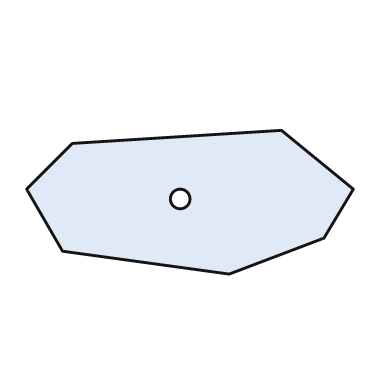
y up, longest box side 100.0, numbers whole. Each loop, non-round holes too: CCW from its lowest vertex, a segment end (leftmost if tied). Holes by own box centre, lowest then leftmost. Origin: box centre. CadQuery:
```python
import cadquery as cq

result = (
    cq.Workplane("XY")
    .moveTo(12.0, -22.0)
    .lineTo(41.0, -11.0)
    .lineTo(50.0, 4.0)
    .lineTo(28.0, 22.0)
    .lineTo(-36.0, 18.0)
    .lineTo(-50.0, 4.0)
    .lineTo(-39.0, -15.0)
    .close()
    .moveTo(-3.0, 1.0)
    .circle(3.0)
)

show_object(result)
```